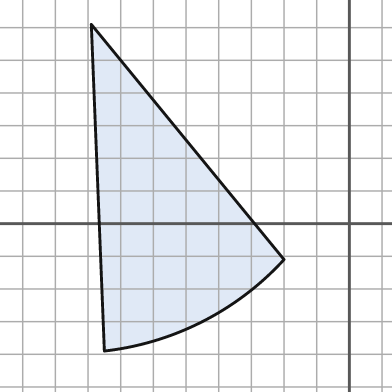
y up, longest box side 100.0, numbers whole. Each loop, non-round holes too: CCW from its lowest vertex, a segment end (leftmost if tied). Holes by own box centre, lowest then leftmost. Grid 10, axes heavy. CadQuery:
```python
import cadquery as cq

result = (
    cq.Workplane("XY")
    .moveTo(-75.0, -39.0)
    .threePointArc((-45.0, -30.0), (-20.0, -11.0))
    .lineTo(-79.0, 61.0)
    .close()
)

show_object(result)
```